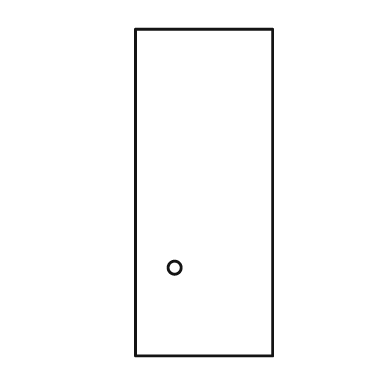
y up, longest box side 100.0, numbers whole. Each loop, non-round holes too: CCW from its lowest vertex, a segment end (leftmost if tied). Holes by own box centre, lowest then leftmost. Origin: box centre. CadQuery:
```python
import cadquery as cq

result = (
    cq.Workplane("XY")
    .moveTo(-21.0, -50.0)
    .lineTo(21.0, -50.0)
    .lineTo(21.0, 50.0)
    .lineTo(-21.0, 50.0)
    .close()
    .moveTo(-9.0, -23.0)
    .circle(2.0)
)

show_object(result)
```